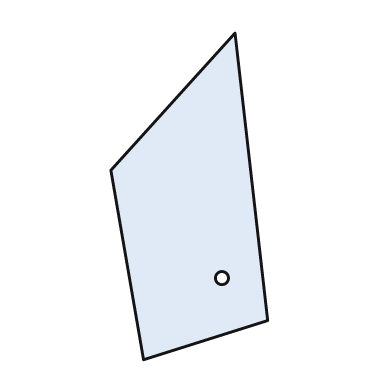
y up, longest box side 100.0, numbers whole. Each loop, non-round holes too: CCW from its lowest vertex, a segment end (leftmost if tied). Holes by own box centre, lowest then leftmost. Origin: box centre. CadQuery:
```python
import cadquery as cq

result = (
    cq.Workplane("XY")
    .moveTo(-14.0, -50.0)
    .lineTo(24.0, -38.0)
    .lineTo(14.0, 50.0)
    .lineTo(-24.0, 8.0)
    .close()
    .moveTo(10.0, -25.0)
    .circle(2.0)
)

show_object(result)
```